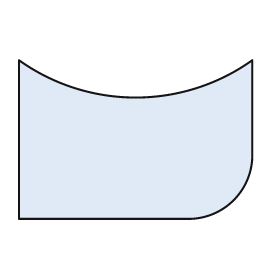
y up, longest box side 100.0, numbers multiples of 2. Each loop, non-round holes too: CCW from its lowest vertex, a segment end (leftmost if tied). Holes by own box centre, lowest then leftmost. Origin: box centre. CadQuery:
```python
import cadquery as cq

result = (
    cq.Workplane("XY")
    .moveTo(-50.0, -34.0)
    .lineTo(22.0, -34.0)
    .threePointArc((42.0, -26.0), (50.0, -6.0))
    .lineTo(50.0, 34.0)
    .threePointArc((0.0, 18.0), (-50.0, 34.0))
    .close()
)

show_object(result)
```